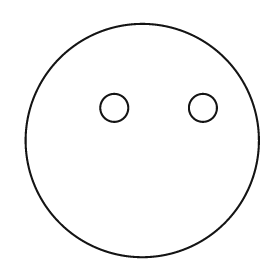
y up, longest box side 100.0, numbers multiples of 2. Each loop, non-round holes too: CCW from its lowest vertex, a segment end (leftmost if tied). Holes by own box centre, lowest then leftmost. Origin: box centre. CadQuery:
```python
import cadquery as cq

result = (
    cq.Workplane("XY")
    .moveTo(0.0, 0.0)
    .circle(50.0)
    .moveTo(-12.0, 14.0)
    .circle(6.0)
    .moveTo(26.0, 14.0)
    .circle(6.0)
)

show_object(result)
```